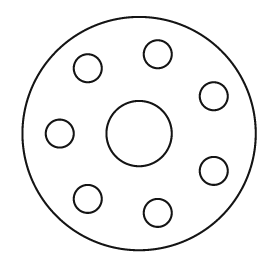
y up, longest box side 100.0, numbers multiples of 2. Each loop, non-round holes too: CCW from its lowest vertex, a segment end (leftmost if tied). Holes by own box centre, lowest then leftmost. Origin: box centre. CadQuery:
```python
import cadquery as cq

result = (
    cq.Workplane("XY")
    .moveTo(0.0, 0.0)
    .circle(50.0)
    .moveTo(8.0, -34.0)
    .circle(6.0)
    .moveTo(-22.0, -28.0)
    .circle(6.0)
    .moveTo(32.0, -16.0)
    .circle(6.0)
    .moveTo(-34.0, 0.0)
    .circle(6.0)
    .moveTo(0.0, 0.0)
    .circle(14.0)
    .moveTo(32.0, 16.0)
    .circle(6.0)
    .moveTo(-22.0, 28.0)
    .circle(6.0)
    .moveTo(8.0, 34.0)
    .circle(6.0)
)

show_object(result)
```